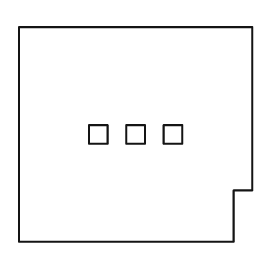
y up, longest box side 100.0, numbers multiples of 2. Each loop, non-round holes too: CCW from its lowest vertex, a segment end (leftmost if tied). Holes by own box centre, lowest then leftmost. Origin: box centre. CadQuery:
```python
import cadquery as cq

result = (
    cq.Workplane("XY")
    .moveTo(-50.0, -46.0)
    .lineTo(42.0, -46.0)
    .lineTo(42.0, -24.0)
    .lineTo(50.0, -24.0)
    .lineTo(50.0, 46.0)
    .lineTo(-50.0, 46.0)
    .close()
    .moveTo(-20.0, -4.0)
    .lineTo(-12.0, -4.0)
    .lineTo(-12.0, 4.0)
    .lineTo(-20.0, 4.0)
    .close()
    .moveTo(-4.0, -4.0)
    .lineTo(4.0, -4.0)
    .lineTo(4.0, 4.0)
    .lineTo(-4.0, 4.0)
    .close()
    .moveTo(12.0, -4.0)
    .lineTo(20.0, -4.0)
    .lineTo(20.0, 4.0)
    .lineTo(12.0, 4.0)
    .close()
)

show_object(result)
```